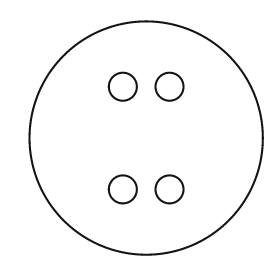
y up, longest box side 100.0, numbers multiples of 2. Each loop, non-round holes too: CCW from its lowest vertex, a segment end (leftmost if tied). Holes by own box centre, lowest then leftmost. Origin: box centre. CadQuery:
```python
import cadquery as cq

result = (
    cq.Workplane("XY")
    .moveTo(0.0, 0.0)
    .circle(50.0)
    .moveTo(-10.0, -22.0)
    .circle(6.0)
    .moveTo(10.0, -22.0)
    .circle(6.0)
    .moveTo(-10.0, 22.0)
    .circle(6.0)
    .moveTo(10.0, 22.0)
    .circle(6.0)
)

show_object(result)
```